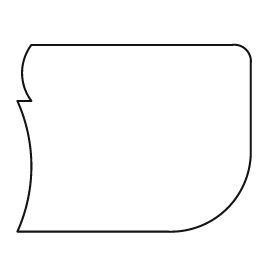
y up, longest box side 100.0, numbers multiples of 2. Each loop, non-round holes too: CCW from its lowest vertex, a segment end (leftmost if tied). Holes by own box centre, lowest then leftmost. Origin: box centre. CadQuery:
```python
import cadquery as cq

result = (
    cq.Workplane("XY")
    .moveTo(-50.0, -40.0)
    .lineTo(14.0, -40.0)
    .threePointArc((40.0, -30.0), (50.0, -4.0))
    .lineTo(50.0, 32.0)
    .threePointArc((48.0, 38.0), (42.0, 40.0))
    .lineTo(-44.0, 40.0)
    .threePointArc((-48.0, 28.0), (-44.0, 16.0))
    .lineTo(-50.0, 16.0)
    .threePointArc((-44.0, -12.0), (-50.0, -40.0))
    .close()
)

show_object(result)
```